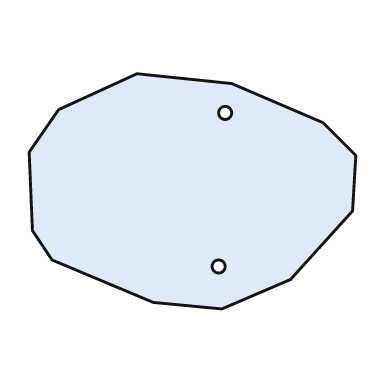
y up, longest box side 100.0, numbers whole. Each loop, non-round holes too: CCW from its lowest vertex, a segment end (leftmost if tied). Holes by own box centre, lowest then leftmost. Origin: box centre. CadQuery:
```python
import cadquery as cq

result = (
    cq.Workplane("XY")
    .moveTo(9.0, -36.0)
    .lineTo(30.0, -27.0)
    .lineTo(49.0, -6.0)
    .lineTo(50.0, 11.0)
    .lineTo(40.0, 21.0)
    .lineTo(12.0, 33.0)
    .lineTo(-17.0, 36.0)
    .lineTo(-41.0, 25.0)
    .lineTo(-50.0, 12.0)
    .lineTo(-49.0, -12.0)
    .lineTo(-43.0, -21.0)
    .lineTo(-12.0, -34.0)
    .close()
    .moveTo(8.0, -23.0)
    .circle(2.0)
    .moveTo(10.0, 24.0)
    .circle(2.0)
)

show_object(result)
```